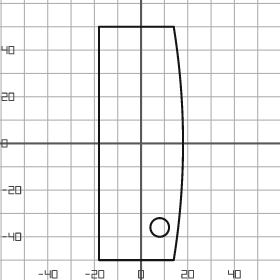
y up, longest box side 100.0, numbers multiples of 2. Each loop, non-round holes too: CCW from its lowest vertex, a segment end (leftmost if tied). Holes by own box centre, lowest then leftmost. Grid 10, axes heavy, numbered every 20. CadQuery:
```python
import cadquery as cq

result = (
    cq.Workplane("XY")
    .moveTo(-18.0, -50.0)
    .lineTo(14.0, -50.0)
    .threePointArc((18.0, 0.0), (14.0, 50.0))
    .lineTo(-18.0, 50.0)
    .close()
    .moveTo(8.0, -36.0)
    .circle(4.0)
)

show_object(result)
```